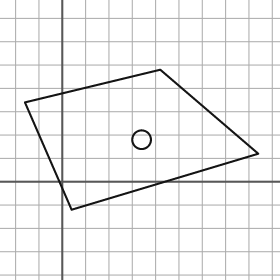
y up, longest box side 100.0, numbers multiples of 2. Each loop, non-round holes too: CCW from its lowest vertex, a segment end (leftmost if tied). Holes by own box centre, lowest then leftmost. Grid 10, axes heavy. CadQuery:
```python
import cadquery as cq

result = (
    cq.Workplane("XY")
    .moveTo(4.0, -12.0)
    .lineTo(84.0, 12.0)
    .lineTo(42.0, 48.0)
    .lineTo(-16.0, 34.0)
    .close()
    .moveTo(34.0, 18.0)
    .circle(4.0)
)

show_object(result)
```